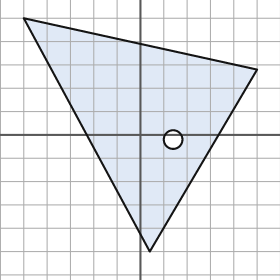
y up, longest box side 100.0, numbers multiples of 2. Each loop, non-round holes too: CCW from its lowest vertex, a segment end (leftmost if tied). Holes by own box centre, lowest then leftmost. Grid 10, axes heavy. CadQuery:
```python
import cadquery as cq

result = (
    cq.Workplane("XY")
    .moveTo(4.0, -50.0)
    .lineTo(50.0, 28.0)
    .lineTo(-50.0, 50.0)
    .close()
    .moveTo(14.0, -2.0)
    .circle(4.0)
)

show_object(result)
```